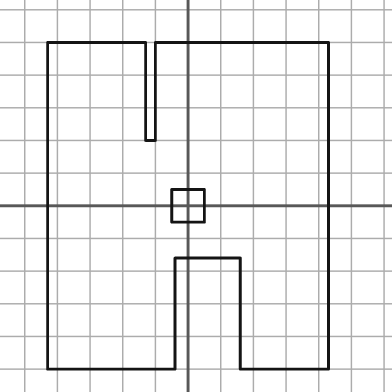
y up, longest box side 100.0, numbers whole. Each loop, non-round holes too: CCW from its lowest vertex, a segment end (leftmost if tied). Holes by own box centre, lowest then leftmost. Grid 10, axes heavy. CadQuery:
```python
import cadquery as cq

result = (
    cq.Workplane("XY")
    .moveTo(-43.0, -50.0)
    .lineTo(-4.0, -50.0)
    .lineTo(-4.0, -16.0)
    .lineTo(16.0, -16.0)
    .lineTo(16.0, -50.0)
    .lineTo(43.0, -50.0)
    .lineTo(43.0, 50.0)
    .lineTo(-10.0, 50.0)
    .lineTo(-10.0, 20.0)
    .lineTo(-13.0, 20.0)
    .lineTo(-13.0, 50.0)
    .lineTo(-43.0, 50.0)
    .close()
    .moveTo(-5.0, -5.0)
    .lineTo(5.0, -5.0)
    .lineTo(5.0, 5.0)
    .lineTo(-5.0, 5.0)
    .close()
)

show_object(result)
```